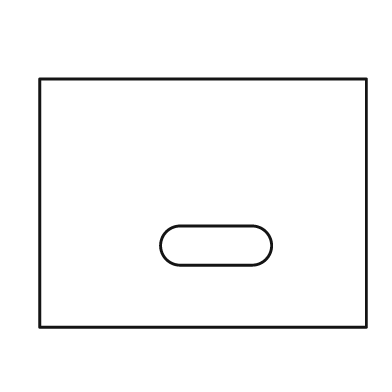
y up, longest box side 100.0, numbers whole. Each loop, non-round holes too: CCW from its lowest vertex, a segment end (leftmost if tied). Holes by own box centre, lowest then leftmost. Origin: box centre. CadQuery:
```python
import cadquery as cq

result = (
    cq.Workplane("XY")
    .moveTo(-50.0, -38.0)
    .lineTo(50.0, -38.0)
    .lineTo(50.0, 38.0)
    .lineTo(-50.0, 38.0)
    .close()
    .moveTo(-7.0, -19.0)
    .lineTo(15.0, -19.0)
    .threePointArc((21.0, -13.0), (15.0, -7.0))
    .lineTo(-7.0, -7.0)
    .threePointArc((-13.0, -13.0), (-7.0, -19.0))
    .close()
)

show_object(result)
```